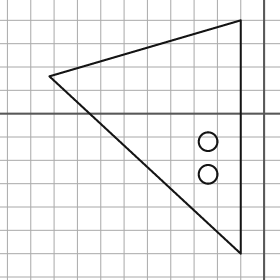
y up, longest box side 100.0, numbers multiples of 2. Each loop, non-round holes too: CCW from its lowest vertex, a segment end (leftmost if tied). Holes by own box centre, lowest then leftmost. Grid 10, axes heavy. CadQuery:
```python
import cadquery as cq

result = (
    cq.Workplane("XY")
    .moveTo(-10.0, -60.0)
    .lineTo(-10.0, 40.0)
    .lineTo(-92.0, 16.0)
    .close()
    .moveTo(-24.0, -26.0)
    .circle(4.0)
    .moveTo(-24.0, -12.0)
    .circle(4.0)
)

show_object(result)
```